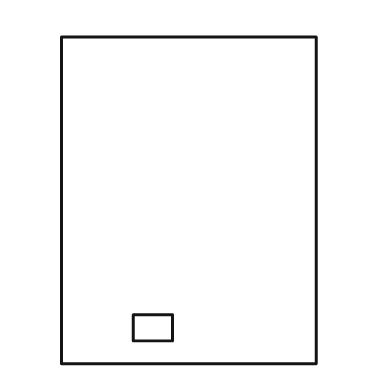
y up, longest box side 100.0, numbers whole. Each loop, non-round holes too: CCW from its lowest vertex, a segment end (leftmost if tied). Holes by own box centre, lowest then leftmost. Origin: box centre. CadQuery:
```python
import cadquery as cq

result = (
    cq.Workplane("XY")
    .moveTo(-39.0, -50.0)
    .lineTo(39.0, -50.0)
    .lineTo(39.0, 50.0)
    .lineTo(-39.0, 50.0)
    .close()
    .moveTo(-17.0, -43.0)
    .lineTo(-5.0, -43.0)
    .lineTo(-5.0, -35.0)
    .lineTo(-17.0, -35.0)
    .close()
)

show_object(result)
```